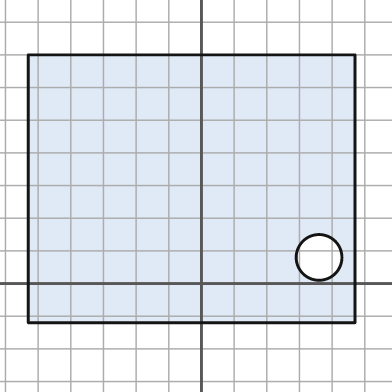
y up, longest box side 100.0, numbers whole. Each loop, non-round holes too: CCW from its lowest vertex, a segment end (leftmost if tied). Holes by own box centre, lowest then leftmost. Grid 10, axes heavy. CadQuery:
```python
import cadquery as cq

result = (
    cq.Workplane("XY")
    .moveTo(-53.0, -12.0)
    .lineTo(47.0, -12.0)
    .lineTo(47.0, 70.0)
    .lineTo(-53.0, 70.0)
    .close()
    .moveTo(36.0, 8.0)
    .circle(7.0)
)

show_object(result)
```